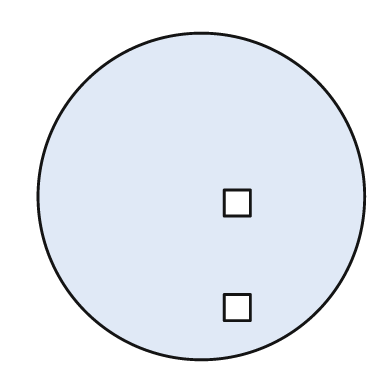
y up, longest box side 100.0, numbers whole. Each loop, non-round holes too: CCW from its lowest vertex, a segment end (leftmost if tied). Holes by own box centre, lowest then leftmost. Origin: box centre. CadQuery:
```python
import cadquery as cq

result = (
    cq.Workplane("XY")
    .moveTo(0.0, 0.0)
    .circle(50.0)
    .moveTo(7.0, -38.0)
    .lineTo(15.0, -38.0)
    .lineTo(15.0, -30.0)
    .lineTo(7.0, -30.0)
    .close()
    .moveTo(7.0, -6.0)
    .lineTo(15.0, -6.0)
    .lineTo(15.0, 2.0)
    .lineTo(7.0, 2.0)
    .close()
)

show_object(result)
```